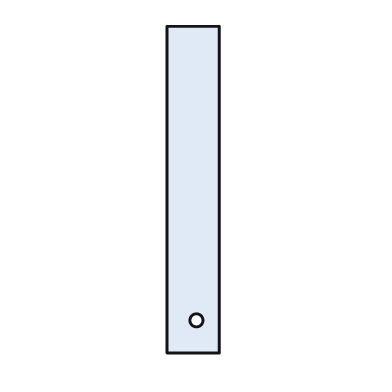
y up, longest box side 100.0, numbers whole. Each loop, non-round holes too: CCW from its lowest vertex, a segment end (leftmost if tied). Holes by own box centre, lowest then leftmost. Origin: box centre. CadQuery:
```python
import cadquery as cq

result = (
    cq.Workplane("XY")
    .moveTo(-8.0, -50.0)
    .lineTo(8.0, -50.0)
    .lineTo(8.0, 50.0)
    .lineTo(-8.0, 50.0)
    .close()
    .moveTo(1.0, -40.0)
    .circle(2.0)
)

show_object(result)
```